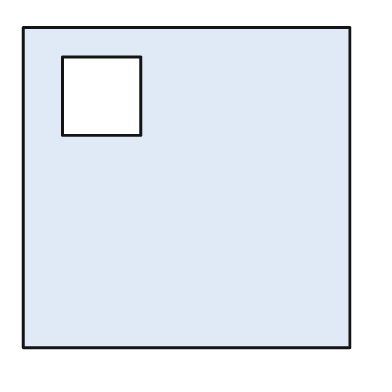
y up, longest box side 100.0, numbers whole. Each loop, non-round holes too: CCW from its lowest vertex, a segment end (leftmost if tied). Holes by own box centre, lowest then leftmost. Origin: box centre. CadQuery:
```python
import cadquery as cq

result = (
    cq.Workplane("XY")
    .moveTo(-50.0, -49.0)
    .lineTo(50.0, -49.0)
    .lineTo(50.0, 49.0)
    .lineTo(-50.0, 49.0)
    .close()
    .moveTo(-38.0, 16.0)
    .lineTo(-14.0, 16.0)
    .lineTo(-14.0, 40.0)
    .lineTo(-38.0, 40.0)
    .close()
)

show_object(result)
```